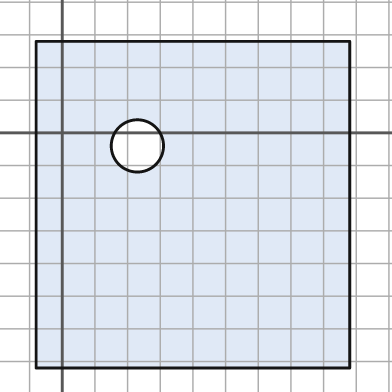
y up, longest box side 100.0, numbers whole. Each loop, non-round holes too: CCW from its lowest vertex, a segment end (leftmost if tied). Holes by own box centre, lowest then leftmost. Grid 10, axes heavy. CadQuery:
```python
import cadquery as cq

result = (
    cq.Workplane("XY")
    .moveTo(-8.0, -72.0)
    .lineTo(88.0, -72.0)
    .lineTo(88.0, 28.0)
    .lineTo(-8.0, 28.0)
    .close()
    .moveTo(23.0, -4.0)
    .circle(8.0)
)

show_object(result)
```